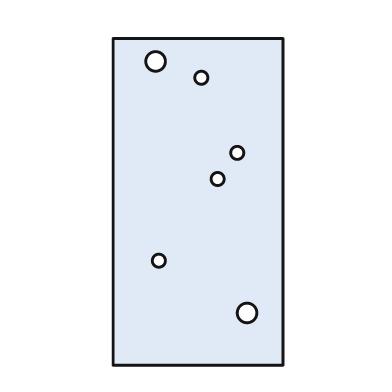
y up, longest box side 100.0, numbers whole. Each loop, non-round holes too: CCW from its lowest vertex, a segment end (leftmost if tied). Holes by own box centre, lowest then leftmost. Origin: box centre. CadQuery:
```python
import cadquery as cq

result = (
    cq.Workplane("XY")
    .moveTo(-26.0, -50.0)
    .lineTo(26.0, -50.0)
    .lineTo(26.0, 50.0)
    .lineTo(-26.0, 50.0)
    .close()
    .moveTo(15.0, -34.0)
    .circle(3.0)
    .moveTo(-12.0, -18.0)
    .circle(2.0)
    .moveTo(6.0, 7.0)
    .circle(2.0)
    .moveTo(12.0, 15.0)
    .circle(2.0)
    .moveTo(1.0, 38.0)
    .circle(2.0)
    .moveTo(-13.0, 43.0)
    .circle(3.0)
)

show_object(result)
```